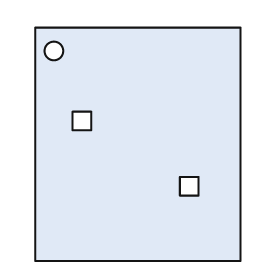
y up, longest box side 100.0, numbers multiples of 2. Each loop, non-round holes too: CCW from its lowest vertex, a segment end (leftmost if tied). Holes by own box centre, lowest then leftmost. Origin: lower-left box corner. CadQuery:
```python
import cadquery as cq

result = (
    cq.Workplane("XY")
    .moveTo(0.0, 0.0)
    .lineTo(88.0, 0.0)
    .lineTo(88.0, 100.0)
    .lineTo(0.0, 100.0)
    .close()
    .moveTo(62.0, 28.0)
    .lineTo(70.0, 28.0)
    .lineTo(70.0, 36.0)
    .lineTo(62.0, 36.0)
    .close()
    .moveTo(16.0, 56.0)
    .lineTo(24.0, 56.0)
    .lineTo(24.0, 64.0)
    .lineTo(16.0, 64.0)
    .close()
    .moveTo(8.0, 90.0)
    .circle(4.0)
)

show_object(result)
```